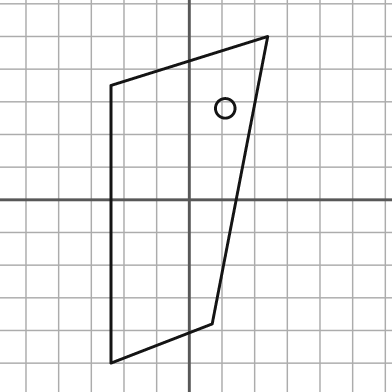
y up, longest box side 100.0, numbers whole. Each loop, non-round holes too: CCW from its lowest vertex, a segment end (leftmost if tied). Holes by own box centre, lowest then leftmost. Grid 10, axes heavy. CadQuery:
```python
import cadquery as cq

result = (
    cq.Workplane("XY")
    .moveTo(-24.0, -50.0)
    .lineTo(7.0, -38.0)
    .lineTo(24.0, 50.0)
    .lineTo(-24.0, 35.0)
    .close()
    .moveTo(11.0, 28.0)
    .circle(3.0)
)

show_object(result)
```